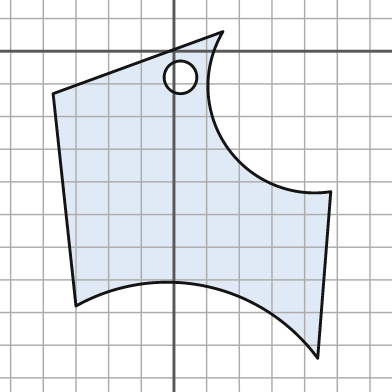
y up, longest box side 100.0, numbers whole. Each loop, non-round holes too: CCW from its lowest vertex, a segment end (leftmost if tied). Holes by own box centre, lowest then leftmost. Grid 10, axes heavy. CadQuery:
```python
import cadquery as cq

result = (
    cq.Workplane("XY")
    .moveTo(44.0, -94.0)
    .lineTo(48.0, -43.0)
    .threePointArc((16.0, -29.0), (15.0, 6.0))
    .lineTo(-37.0, -13.0)
    .lineTo(-30.0, -78.0)
    .threePointArc((10.0, -72.0), (44.0, -94.0))
    .close()
    .moveTo(2.0, -8.0)
    .circle(5.0)
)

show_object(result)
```